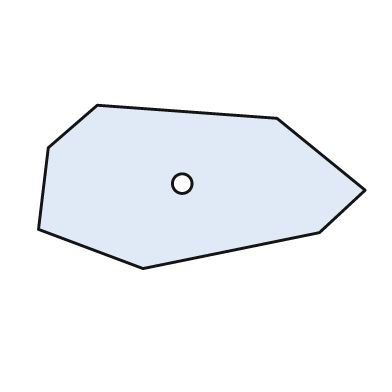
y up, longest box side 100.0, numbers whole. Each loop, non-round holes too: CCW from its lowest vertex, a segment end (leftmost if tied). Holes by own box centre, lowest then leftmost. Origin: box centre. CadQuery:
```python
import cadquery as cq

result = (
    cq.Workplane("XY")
    .moveTo(-18.0, -25.0)
    .lineTo(36.0, -14.0)
    .lineTo(50.0, -1.0)
    .lineTo(23.0, 21.0)
    .lineTo(-32.0, 25.0)
    .lineTo(-47.0, 12.0)
    .lineTo(-50.0, -13.0)
    .close()
    .moveTo(-6.0, 1.0)
    .circle(3.0)
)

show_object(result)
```